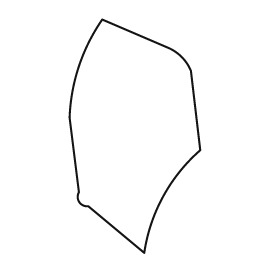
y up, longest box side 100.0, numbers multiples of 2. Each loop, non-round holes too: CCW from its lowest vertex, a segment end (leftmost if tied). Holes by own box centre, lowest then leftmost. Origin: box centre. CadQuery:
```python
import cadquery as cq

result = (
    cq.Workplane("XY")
    .moveTo(4.0, -50.0)
    .threePointArc((12.0, -26.0), (28.0, -6.0))
    .lineTo(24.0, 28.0)
    .threePointArc((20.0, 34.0), (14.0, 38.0))
    .lineTo(-14.0, 50.0)
    .threePointArc((-24.0, 30.0), (-28.0, 8.0))
    .lineTo(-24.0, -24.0)
    .threePointArc((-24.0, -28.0), (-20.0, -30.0))
    .close()
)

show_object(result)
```